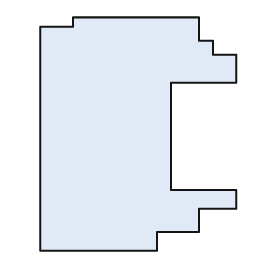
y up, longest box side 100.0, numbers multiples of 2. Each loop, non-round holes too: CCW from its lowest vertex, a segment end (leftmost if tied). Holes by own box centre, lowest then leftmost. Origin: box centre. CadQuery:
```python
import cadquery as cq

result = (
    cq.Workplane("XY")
    .moveTo(-42.0, -50.0)
    .lineTo(8.0, -50.0)
    .lineTo(8.0, -42.0)
    .lineTo(26.0, -42.0)
    .lineTo(26.0, -32.0)
    .lineTo(42.0, -32.0)
    .lineTo(42.0, -24.0)
    .lineTo(14.0, -24.0)
    .lineTo(14.0, 22.0)
    .lineTo(42.0, 22.0)
    .lineTo(42.0, 34.0)
    .lineTo(32.0, 34.0)
    .lineTo(32.0, 40.0)
    .lineTo(26.0, 40.0)
    .lineTo(26.0, 50.0)
    .lineTo(-28.0, 50.0)
    .lineTo(-28.0, 46.0)
    .lineTo(-42.0, 46.0)
    .close()
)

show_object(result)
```